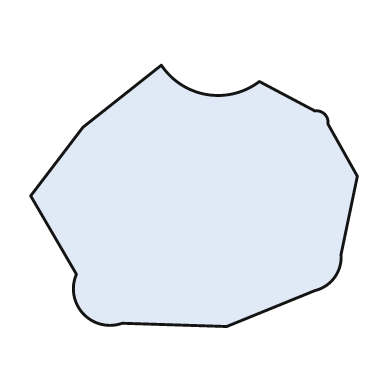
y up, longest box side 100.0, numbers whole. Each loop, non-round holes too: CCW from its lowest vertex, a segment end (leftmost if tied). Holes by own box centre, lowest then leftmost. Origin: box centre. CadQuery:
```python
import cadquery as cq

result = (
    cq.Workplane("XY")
    .moveTo(10.0, -40.0)
    .lineTo(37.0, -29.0)
    .threePointArc((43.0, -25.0), (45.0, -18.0))
    .lineTo(50.0, 6.0)
    .lineTo(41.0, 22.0)
    .threePointArc((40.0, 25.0), (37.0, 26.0))
    .lineTo(20.0, 35.0)
    .threePointArc((4.0, 31.0), (-10.0, 40.0))
    .lineTo(-34.0, 21.0)
    .lineTo(-50.0, 0.0)
    .lineTo(-36.0, -24.0)
    .threePointArc((-34.0, -36.0), (-22.0, -39.0))
    .close()
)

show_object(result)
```